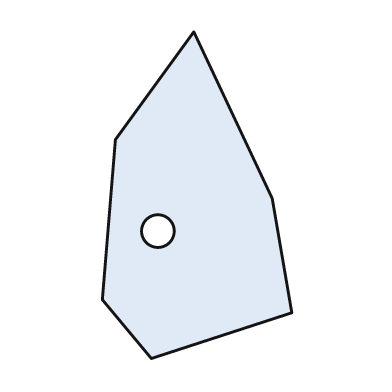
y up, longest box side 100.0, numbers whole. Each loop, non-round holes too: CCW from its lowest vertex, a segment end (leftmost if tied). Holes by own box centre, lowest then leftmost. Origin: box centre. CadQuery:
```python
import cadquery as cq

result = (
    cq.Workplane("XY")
    .moveTo(-14.0, -50.0)
    .lineTo(29.0, -36.0)
    .lineTo(23.0, -1.0)
    .lineTo(-1.0, 50.0)
    .lineTo(-25.0, 17.0)
    .lineTo(-29.0, -32.0)
    .close()
    .moveTo(-12.0, -11.0)
    .circle(5.0)
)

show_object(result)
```